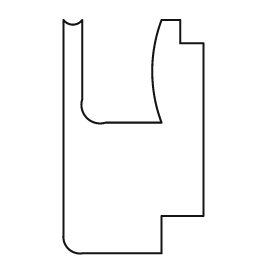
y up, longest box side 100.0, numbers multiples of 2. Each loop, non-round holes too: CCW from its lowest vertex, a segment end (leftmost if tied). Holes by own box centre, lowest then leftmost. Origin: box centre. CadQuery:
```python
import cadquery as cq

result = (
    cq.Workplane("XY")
    .moveTo(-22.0, -50.0)
    .lineTo(12.0, -50.0)
    .lineTo(12.0, -34.0)
    .lineTo(30.0, -34.0)
    .lineTo(30.0, 40.0)
    .lineTo(20.0, 40.0)
    .lineTo(20.0, 50.0)
    .lineTo(12.0, 50.0)
    .threePointArc((8.0, 28.0), (12.0, 6.0))
    .lineTo(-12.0, 6.0)
    .threePointArc((-20.0, 8.0), (-22.0, 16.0))
    .lineTo(-22.0, 50.0)
    .threePointArc((-26.0, 48.0), (-30.0, 50.0))
    .lineTo(-30.0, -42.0)
    .threePointArc((-28.0, -48.0), (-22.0, -50.0))
    .close()
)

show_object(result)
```